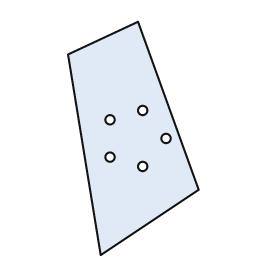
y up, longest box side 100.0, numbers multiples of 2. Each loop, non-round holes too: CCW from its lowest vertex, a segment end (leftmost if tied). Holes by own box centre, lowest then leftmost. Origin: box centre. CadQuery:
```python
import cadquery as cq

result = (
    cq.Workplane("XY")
    .moveTo(-14.0, -50.0)
    .lineTo(28.0, -22.0)
    .lineTo(2.0, 50.0)
    .lineTo(-28.0, 36.0)
    .close()
    .moveTo(4.0, -12.0)
    .circle(2.0)
    .moveTo(-10.0, -8.0)
    .circle(2.0)
    .moveTo(14.0, 0.0)
    .circle(2.0)
    .moveTo(-10.0, 8.0)
    .circle(2.0)
    .moveTo(4.0, 12.0)
    .circle(2.0)
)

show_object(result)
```